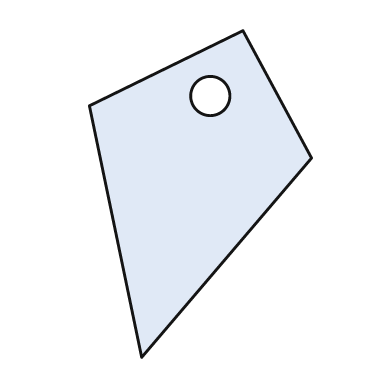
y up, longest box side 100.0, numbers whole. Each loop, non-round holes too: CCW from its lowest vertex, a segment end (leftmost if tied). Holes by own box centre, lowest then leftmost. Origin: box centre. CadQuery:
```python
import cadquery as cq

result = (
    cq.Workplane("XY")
    .moveTo(-18.0, -50.0)
    .lineTo(34.0, 11.0)
    .lineTo(13.0, 50.0)
    .lineTo(-34.0, 27.0)
    .close()
    .moveTo(3.0, 30.0)
    .circle(6.0)
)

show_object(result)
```